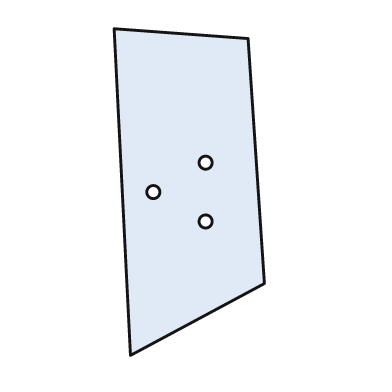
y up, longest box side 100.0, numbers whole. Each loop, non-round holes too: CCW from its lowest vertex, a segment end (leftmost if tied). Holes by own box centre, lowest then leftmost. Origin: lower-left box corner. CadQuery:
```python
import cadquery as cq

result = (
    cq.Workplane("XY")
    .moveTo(5.0, 0.0)
    .lineTo(46.0, 22.0)
    .lineTo(41.0, 97.0)
    .lineTo(0.0, 100.0)
    .close()
    .moveTo(28.0, 41.0)
    .circle(2.0)
    .moveTo(12.0, 50.0)
    .circle(2.0)
    .moveTo(28.0, 59.0)
    .circle(2.0)
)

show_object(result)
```